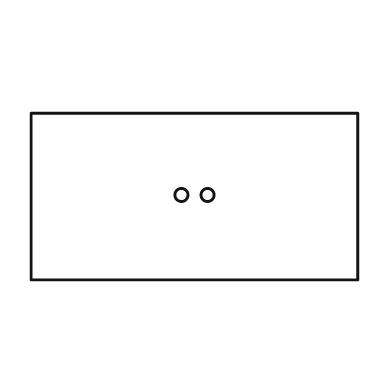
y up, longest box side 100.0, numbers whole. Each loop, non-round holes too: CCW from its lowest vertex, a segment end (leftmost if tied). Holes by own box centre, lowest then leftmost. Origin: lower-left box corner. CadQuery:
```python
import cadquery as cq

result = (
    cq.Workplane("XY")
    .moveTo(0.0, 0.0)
    .lineTo(100.0, 0.0)
    .lineTo(100.0, 51.0)
    .lineTo(0.0, 51.0)
    .close()
    .moveTo(46.0, 26.0)
    .circle(2.0)
    .moveTo(54.0, 26.0)
    .circle(2.0)
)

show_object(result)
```